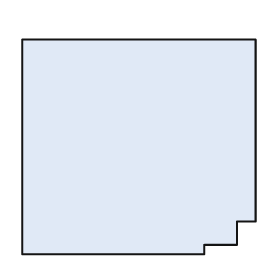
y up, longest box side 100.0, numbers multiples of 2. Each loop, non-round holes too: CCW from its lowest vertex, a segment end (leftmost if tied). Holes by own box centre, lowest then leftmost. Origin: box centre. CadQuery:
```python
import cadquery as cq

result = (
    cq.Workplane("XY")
    .moveTo(-50.0, -46.0)
    .lineTo(28.0, -46.0)
    .lineTo(28.0, -42.0)
    .lineTo(42.0, -42.0)
    .lineTo(42.0, -32.0)
    .lineTo(50.0, -32.0)
    .lineTo(50.0, 46.0)
    .lineTo(-50.0, 46.0)
    .close()
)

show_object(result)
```